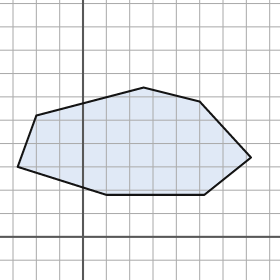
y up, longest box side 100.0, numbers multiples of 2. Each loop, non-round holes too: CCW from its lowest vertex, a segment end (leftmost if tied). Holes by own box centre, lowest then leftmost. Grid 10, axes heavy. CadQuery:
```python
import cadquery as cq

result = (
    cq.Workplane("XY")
    .moveTo(10.0, 18.0)
    .lineTo(52.0, 18.0)
    .lineTo(72.0, 34.0)
    .lineTo(50.0, 58.0)
    .lineTo(26.0, 64.0)
    .lineTo(-20.0, 52.0)
    .lineTo(-28.0, 30.0)
    .close()
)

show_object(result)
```